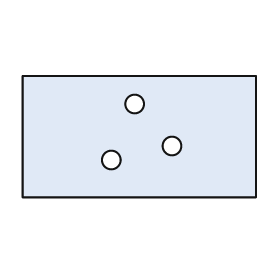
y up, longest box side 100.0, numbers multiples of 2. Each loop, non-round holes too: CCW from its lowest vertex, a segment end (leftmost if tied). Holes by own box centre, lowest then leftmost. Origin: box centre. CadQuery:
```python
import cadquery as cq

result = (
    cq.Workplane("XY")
    .moveTo(-50.0, -26.0)
    .lineTo(50.0, -26.0)
    .lineTo(50.0, 26.0)
    .lineTo(-50.0, 26.0)
    .close()
    .moveTo(-12.0, -10.0)
    .circle(4.0)
    .moveTo(14.0, -4.0)
    .circle(4.0)
    .moveTo(-2.0, 14.0)
    .circle(4.0)
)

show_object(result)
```